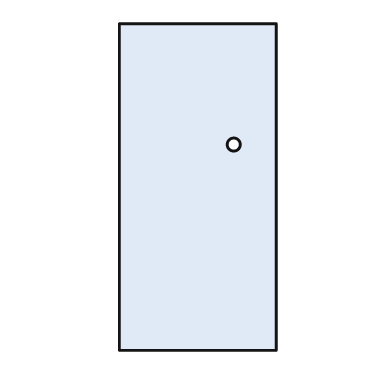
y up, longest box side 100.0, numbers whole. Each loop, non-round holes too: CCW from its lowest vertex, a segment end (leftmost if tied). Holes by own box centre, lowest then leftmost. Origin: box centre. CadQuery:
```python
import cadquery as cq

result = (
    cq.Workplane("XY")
    .moveTo(-24.0, -50.0)
    .lineTo(24.0, -50.0)
    .lineTo(24.0, 50.0)
    .lineTo(-24.0, 50.0)
    .close()
    .moveTo(11.0, 13.0)
    .circle(2.0)
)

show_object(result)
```